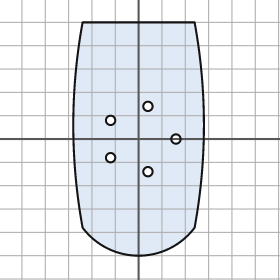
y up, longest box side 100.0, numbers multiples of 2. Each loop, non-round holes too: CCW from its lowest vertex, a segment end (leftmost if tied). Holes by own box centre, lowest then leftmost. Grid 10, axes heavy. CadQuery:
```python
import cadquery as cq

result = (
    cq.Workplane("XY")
    .moveTo(-24.0, -38.0)
    .threePointArc((0.0, -50.0), (24.0, -38.0))
    .threePointArc((28.0, 6.0), (24.0, 50.0))
    .lineTo(-24.0, 50.0)
    .threePointArc((-28.0, 6.0), (-24.0, -38.0))
    .close()
    .moveTo(4.0, -14.0)
    .circle(2.0)
    .moveTo(-12.0, -8.0)
    .circle(2.0)
    .moveTo(16.0, 0.0)
    .circle(2.0)
    .moveTo(-12.0, 8.0)
    .circle(2.0)
    .moveTo(4.0, 14.0)
    .circle(2.0)
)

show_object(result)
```